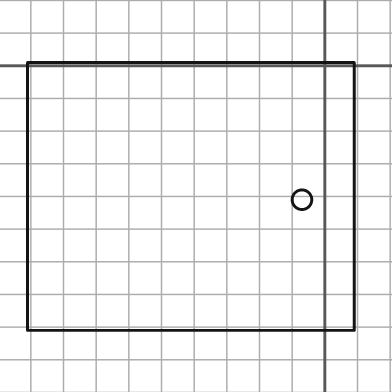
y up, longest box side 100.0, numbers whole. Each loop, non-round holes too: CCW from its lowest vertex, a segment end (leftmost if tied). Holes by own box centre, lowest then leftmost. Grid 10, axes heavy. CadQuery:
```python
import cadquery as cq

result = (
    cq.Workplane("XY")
    .moveTo(-91.0, -81.0)
    .lineTo(9.0, -81.0)
    .lineTo(9.0, 1.0)
    .lineTo(-91.0, 1.0)
    .close()
    .moveTo(-7.0, -41.0)
    .circle(3.0)
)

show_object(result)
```